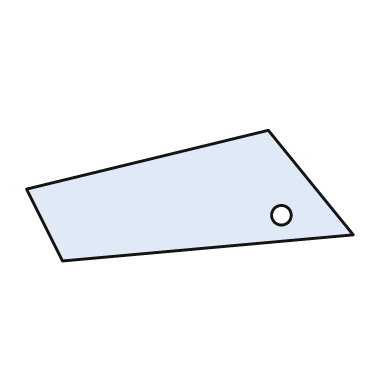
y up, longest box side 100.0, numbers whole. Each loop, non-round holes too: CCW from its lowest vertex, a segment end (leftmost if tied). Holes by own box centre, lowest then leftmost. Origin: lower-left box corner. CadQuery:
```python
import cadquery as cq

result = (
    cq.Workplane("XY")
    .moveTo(11.0, 0.0)
    .lineTo(100.0, 8.0)
    .lineTo(74.0, 40.0)
    .lineTo(0.0, 22.0)
    .close()
    .moveTo(78.0, 14.0)
    .circle(3.0)
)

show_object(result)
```